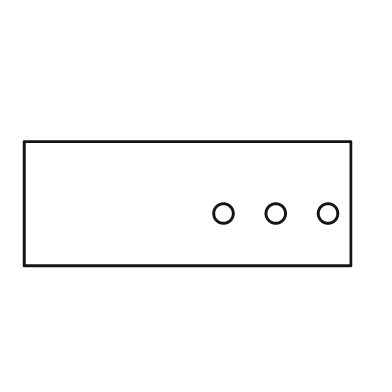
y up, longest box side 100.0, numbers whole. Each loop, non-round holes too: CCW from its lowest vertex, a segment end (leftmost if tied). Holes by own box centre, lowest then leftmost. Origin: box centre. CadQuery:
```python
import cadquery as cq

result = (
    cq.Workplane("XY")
    .moveTo(-50.0, -19.0)
    .lineTo(50.0, -19.0)
    .lineTo(50.0, 19.0)
    .lineTo(-50.0, 19.0)
    .close()
    .moveTo(11.0, -3.0)
    .circle(3.0)
    .moveTo(27.0, -3.0)
    .circle(3.0)
    .moveTo(43.0, -3.0)
    .circle(3.0)
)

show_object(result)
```